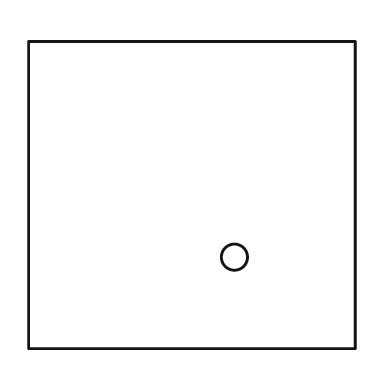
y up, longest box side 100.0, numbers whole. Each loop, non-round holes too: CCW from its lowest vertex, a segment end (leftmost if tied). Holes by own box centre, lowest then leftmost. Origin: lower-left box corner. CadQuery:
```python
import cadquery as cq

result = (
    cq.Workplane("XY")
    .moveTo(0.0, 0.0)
    .lineTo(100.0, 0.0)
    .lineTo(100.0, 94.0)
    .lineTo(0.0, 94.0)
    .close()
    .moveTo(63.0, 28.0)
    .circle(4.0)
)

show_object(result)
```